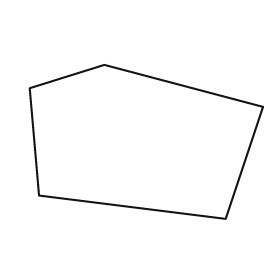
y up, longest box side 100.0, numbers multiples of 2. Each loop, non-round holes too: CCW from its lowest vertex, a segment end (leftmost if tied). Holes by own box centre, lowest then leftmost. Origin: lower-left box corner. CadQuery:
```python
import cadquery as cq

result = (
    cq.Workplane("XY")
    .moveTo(84.0, 0.0)
    .lineTo(100.0, 48.0)
    .lineTo(32.0, 66.0)
    .lineTo(0.0, 56.0)
    .lineTo(4.0, 10.0)
    .close()
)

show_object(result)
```